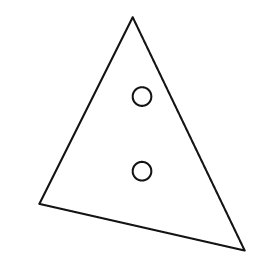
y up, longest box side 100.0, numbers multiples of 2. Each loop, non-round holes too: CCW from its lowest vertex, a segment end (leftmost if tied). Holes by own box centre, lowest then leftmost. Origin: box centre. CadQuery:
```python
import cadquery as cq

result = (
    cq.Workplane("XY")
    .moveTo(44.0, -50.0)
    .lineTo(-4.0, 50.0)
    .lineTo(-44.0, -30.0)
    .close()
    .moveTo(0.0, -16.0)
    .circle(4.0)
    .moveTo(0.0, 16.0)
    .circle(4.0)
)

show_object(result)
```